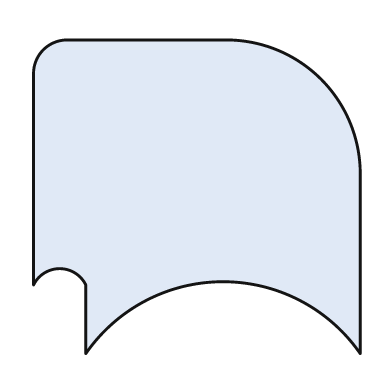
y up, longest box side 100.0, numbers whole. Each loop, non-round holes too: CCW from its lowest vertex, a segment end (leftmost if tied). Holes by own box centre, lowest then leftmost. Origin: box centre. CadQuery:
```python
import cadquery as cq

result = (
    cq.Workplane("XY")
    .moveTo(-34.0, -48.0)
    .threePointArc((8.0, -26.0), (50.0, -48.0))
    .lineTo(50.0, 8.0)
    .threePointArc((38.0, 36.0), (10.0, 48.0))
    .lineTo(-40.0, 48.0)
    .threePointArc((-47.0, 45.0), (-50.0, 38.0))
    .lineTo(-50.0, -27.0)
    .threePointArc((-42.0, -22.0), (-34.0, -27.0))
    .close()
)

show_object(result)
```